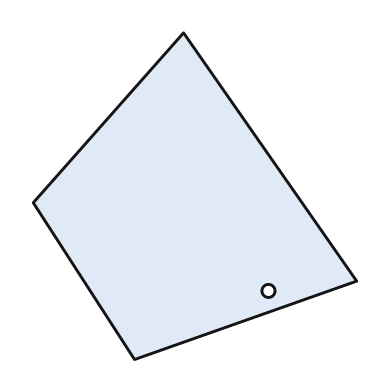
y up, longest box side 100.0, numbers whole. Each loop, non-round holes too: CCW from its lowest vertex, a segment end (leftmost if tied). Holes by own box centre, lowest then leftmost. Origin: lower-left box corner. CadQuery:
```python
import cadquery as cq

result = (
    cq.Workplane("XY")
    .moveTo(31.0, 0.0)
    .lineTo(99.0, 24.0)
    .lineTo(46.0, 100.0)
    .lineTo(0.0, 48.0)
    .close()
    .moveTo(72.0, 21.0)
    .circle(2.0)
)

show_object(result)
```